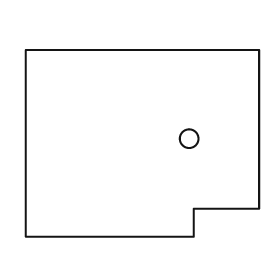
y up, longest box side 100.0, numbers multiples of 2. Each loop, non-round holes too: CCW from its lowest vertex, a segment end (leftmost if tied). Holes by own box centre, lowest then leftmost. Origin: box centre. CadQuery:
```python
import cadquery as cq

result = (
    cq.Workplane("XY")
    .moveTo(-50.0, -40.0)
    .lineTo(22.0, -40.0)
    .lineTo(22.0, -28.0)
    .lineTo(50.0, -28.0)
    .lineTo(50.0, 40.0)
    .lineTo(-50.0, 40.0)
    .close()
    .moveTo(20.0, 2.0)
    .circle(4.0)
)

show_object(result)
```